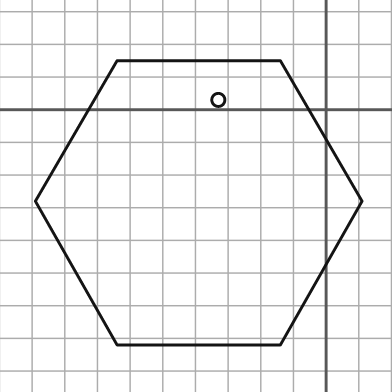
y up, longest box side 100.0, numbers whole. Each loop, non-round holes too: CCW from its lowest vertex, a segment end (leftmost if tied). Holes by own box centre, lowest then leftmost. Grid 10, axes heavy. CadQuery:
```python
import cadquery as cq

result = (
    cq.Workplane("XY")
    .moveTo(-64.0, -72.0)
    .lineTo(-14.0, -72.0)
    .lineTo(11.0, -28.0)
    .lineTo(-14.0, 15.0)
    .lineTo(-64.0, 15.0)
    .lineTo(-89.0, -28.0)
    .close()
    .moveTo(-33.0, 3.0)
    .circle(2.0)
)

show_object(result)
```